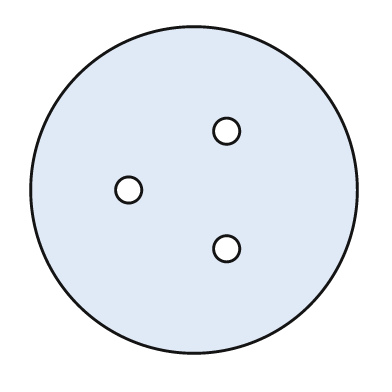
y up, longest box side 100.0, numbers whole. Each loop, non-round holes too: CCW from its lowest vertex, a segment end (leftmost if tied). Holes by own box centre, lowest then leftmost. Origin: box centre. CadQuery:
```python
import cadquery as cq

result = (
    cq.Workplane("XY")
    .moveTo(0.0, 0.0)
    .circle(50.0)
    .moveTo(10.0, -18.0)
    .circle(4.0)
    .moveTo(-20.0, 0.0)
    .circle(4.0)
    .moveTo(10.0, 18.0)
    .circle(4.0)
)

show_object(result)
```